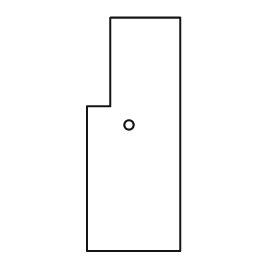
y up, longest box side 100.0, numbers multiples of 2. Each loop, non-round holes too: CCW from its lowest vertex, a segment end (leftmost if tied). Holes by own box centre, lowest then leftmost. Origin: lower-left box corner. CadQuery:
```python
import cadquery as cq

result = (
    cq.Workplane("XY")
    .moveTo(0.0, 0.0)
    .lineTo(40.0, 0.0)
    .lineTo(40.0, 100.0)
    .lineTo(10.0, 100.0)
    .lineTo(10.0, 62.0)
    .lineTo(0.0, 62.0)
    .close()
    .moveTo(18.0, 54.0)
    .circle(2.0)
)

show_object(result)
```